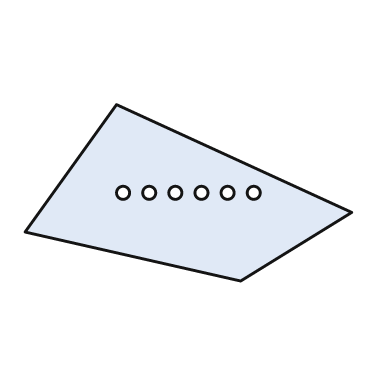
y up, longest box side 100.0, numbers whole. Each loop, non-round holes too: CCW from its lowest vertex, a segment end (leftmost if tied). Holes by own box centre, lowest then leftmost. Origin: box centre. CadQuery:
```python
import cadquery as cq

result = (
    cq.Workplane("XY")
    .moveTo(16.0, -27.0)
    .lineTo(50.0, -6.0)
    .lineTo(-22.0, 27.0)
    .lineTo(-50.0, -12.0)
    .close()
    .moveTo(-20.0, 0.0)
    .circle(2.0)
    .moveTo(-12.0, 0.0)
    .circle(2.0)
    .moveTo(-4.0, 0.0)
    .circle(2.0)
    .moveTo(4.0, 0.0)
    .circle(2.0)
    .moveTo(12.0, 0.0)
    .circle(2.0)
    .moveTo(20.0, 0.0)
    .circle(2.0)
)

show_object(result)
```